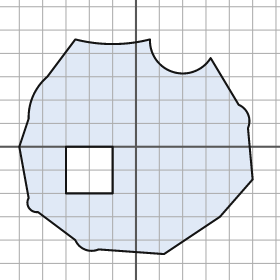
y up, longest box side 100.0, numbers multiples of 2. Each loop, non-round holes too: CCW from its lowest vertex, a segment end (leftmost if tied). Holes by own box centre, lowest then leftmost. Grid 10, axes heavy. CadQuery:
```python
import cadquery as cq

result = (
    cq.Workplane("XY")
    .moveTo(12.0, -46.0)
    .lineTo(36.0, -30.0)
    .lineTo(50.0, -14.0)
    .lineTo(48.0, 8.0)
    .threePointArc((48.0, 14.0), (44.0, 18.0))
    .lineTo(32.0, 38.0)
    .threePointArc((16.0, 32.0), (6.0, 46.0))
    .threePointArc((-10.0, 44.0), (-26.0, 46.0))
    .lineTo(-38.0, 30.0)
    .threePointArc((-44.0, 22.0), (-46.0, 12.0))
    .lineTo(-50.0, 0.0)
    .lineTo(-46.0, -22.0)
    .threePointArc((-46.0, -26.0), (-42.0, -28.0))
    .lineTo(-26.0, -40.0)
    .threePointArc((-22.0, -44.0), (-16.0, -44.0))
    .close()
    .moveTo(-30.0, -20.0)
    .lineTo(-10.0, -20.0)
    .lineTo(-10.0, 0.0)
    .lineTo(-30.0, 0.0)
    .close()
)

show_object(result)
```